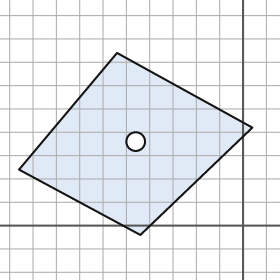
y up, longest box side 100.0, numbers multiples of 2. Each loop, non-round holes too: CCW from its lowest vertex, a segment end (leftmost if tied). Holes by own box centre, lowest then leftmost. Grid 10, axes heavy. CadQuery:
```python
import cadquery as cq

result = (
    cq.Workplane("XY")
    .moveTo(-44.0, -4.0)
    .lineTo(4.0, 42.0)
    .lineTo(-54.0, 74.0)
    .lineTo(-96.0, 24.0)
    .close()
    .moveTo(-46.0, 36.0)
    .circle(4.0)
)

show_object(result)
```